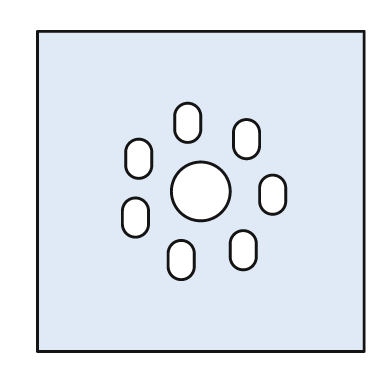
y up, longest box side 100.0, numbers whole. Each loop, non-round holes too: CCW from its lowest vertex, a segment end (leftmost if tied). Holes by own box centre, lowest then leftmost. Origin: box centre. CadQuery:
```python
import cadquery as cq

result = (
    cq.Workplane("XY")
    .moveTo(-50.0, -49.0)
    .lineTo(50.0, -49.0)
    .lineTo(50.0, 49.0)
    .lineTo(-50.0, 49.0)
    .close()
    .moveTo(-10.0, -23.0)
    .threePointArc((-6.0, -27.0), (-2.0, -23.0))
    .lineTo(-2.0, -19.0)
    .threePointArc((-6.0, -15.0), (-10.0, -19.0))
    .close()
    .moveTo(9.0, -20.0)
    .threePointArc((13.0, -24.0), (17.0, -20.0))
    .lineTo(17.0, -16.0)
    .threePointArc((13.0, -12.0), (9.0, -16.0))
    .close()
    .moveTo(-24.0, -10.0)
    .threePointArc((-20.0, -14.0), (-16.0, -10.0))
    .lineTo(-16.0, -6.0)
    .threePointArc((-20.0, -2.0), (-24.0, -6.0))
    .close()
    .moveTo(18.0, -3.0)
    .threePointArc((22.0, -7.0), (26.0, -3.0))
    .lineTo(26.0, 1.0)
    .threePointArc((22.0, 5.0), (18.0, 1.0))
    .close()
    .moveTo(0.0, 0.0)
    .circle(9.0)
    .moveTo(-23.0, 8.0)
    .threePointArc((-19.0, 4.0), (-15.0, 8.0))
    .lineTo(-15.0, 12.0)
    .threePointArc((-19.0, 16.0), (-23.0, 12.0))
    .close()
    .moveTo(10.0, 14.0)
    .threePointArc((14.0, 10.0), (18.0, 14.0))
    .lineTo(18.0, 18.0)
    .threePointArc((14.0, 22.0), (10.0, 18.0))
    .close()
    .moveTo(-8.0, 19.0)
    .threePointArc((-4.0, 15.0), (0.0, 19.0))
    .lineTo(0.0, 23.0)
    .threePointArc((-4.0, 27.0), (-8.0, 23.0))
    .close()
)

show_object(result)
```